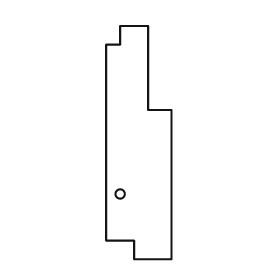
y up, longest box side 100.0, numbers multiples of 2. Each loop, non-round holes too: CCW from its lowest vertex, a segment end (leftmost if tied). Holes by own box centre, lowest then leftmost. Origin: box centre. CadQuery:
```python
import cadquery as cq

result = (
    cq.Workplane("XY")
    .moveTo(-2.0, -50.0)
    .lineTo(14.0, -50.0)
    .lineTo(14.0, 14.0)
    .lineTo(4.0, 14.0)
    .lineTo(4.0, 50.0)
    .lineTo(-8.0, 50.0)
    .lineTo(-8.0, 42.0)
    .lineTo(-14.0, 42.0)
    .lineTo(-14.0, -42.0)
    .lineTo(-2.0, -42.0)
    .close()
    .moveTo(-8.0, -22.0)
    .circle(2.0)
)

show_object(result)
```